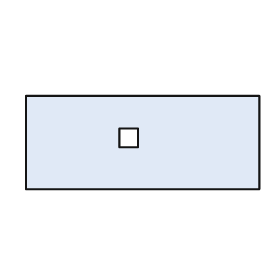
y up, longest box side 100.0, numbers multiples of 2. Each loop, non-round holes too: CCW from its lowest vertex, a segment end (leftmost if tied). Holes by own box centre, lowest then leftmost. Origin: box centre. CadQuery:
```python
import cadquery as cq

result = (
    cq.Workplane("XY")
    .moveTo(-50.0, -20.0)
    .lineTo(50.0, -20.0)
    .lineTo(50.0, 20.0)
    .lineTo(-50.0, 20.0)
    .close()
    .moveTo(-10.0, -2.0)
    .lineTo(-2.0, -2.0)
    .lineTo(-2.0, 6.0)
    .lineTo(-10.0, 6.0)
    .close()
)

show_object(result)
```